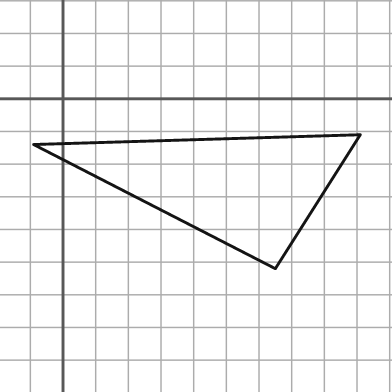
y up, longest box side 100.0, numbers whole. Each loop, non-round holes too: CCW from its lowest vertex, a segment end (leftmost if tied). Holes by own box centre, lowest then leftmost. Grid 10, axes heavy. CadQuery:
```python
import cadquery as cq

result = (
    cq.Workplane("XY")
    .moveTo(65.0, -52.0)
    .lineTo(91.0, -11.0)
    .lineTo(-9.0, -14.0)
    .close()
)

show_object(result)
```